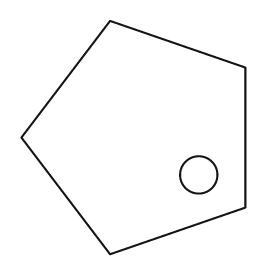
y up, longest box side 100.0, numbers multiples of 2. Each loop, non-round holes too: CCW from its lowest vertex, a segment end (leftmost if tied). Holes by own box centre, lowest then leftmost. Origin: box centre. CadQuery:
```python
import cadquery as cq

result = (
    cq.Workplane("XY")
    .moveTo(-10.0, -50.0)
    .lineTo(48.0, -30.0)
    .lineTo(48.0, 30.0)
    .lineTo(-10.0, 50.0)
    .lineTo(-48.0, 0.0)
    .close()
    .moveTo(28.0, -16.0)
    .circle(8.0)
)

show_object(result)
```